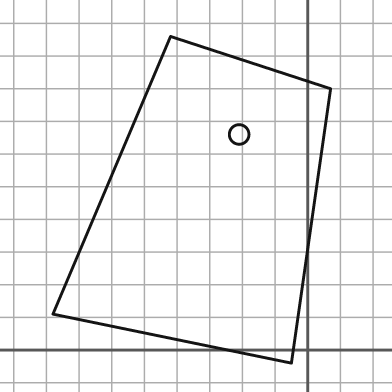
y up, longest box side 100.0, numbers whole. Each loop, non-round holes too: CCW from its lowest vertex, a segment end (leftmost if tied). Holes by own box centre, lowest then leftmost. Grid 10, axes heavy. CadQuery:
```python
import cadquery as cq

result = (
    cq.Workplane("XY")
    .moveTo(-5.0, -4.0)
    .lineTo(7.0, 80.0)
    .lineTo(-42.0, 96.0)
    .lineTo(-78.0, 11.0)
    .close()
    .moveTo(-21.0, 66.0)
    .circle(3.0)
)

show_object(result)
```